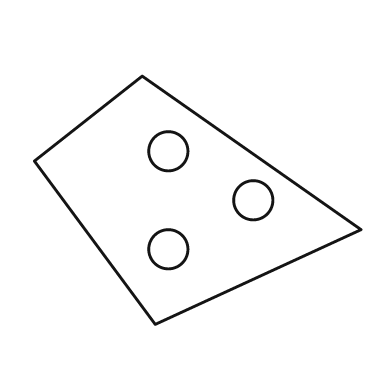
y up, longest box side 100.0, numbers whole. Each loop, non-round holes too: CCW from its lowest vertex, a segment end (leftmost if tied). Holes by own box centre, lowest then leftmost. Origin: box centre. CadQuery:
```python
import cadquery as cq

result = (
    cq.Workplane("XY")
    .moveTo(-13.0, -38.0)
    .lineTo(50.0, -9.0)
    .lineTo(-17.0, 38.0)
    .lineTo(-50.0, 12.0)
    .close()
    .moveTo(-9.0, -15.0)
    .circle(6.0)
    .moveTo(17.0, 0.0)
    .circle(6.0)
    .moveTo(-9.0, 15.0)
    .circle(6.0)
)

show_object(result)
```